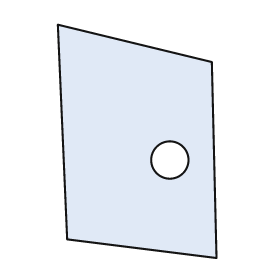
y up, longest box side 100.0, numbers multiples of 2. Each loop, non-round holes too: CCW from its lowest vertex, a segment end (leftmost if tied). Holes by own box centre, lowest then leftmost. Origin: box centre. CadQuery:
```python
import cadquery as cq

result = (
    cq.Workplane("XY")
    .moveTo(34.0, -50.0)
    .lineTo(32.0, 34.0)
    .lineTo(-34.0, 50.0)
    .lineTo(-30.0, -42.0)
    .close()
    .moveTo(14.0, -8.0)
    .circle(8.0)
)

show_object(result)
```